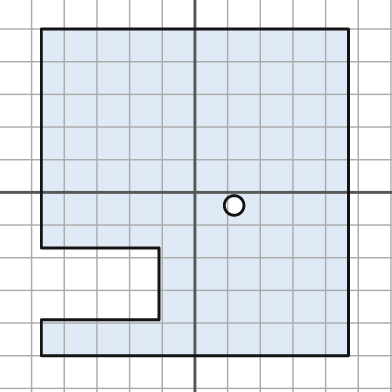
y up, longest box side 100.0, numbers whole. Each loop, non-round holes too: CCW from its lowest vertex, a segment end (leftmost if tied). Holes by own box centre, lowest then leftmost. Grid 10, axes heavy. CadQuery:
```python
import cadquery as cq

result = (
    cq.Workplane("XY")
    .moveTo(-47.0, -50.0)
    .lineTo(47.0, -50.0)
    .lineTo(47.0, 50.0)
    .lineTo(-47.0, 50.0)
    .lineTo(-47.0, -17.0)
    .lineTo(-11.0, -17.0)
    .lineTo(-11.0, -39.0)
    .lineTo(-47.0, -39.0)
    .close()
    .moveTo(12.0, -4.0)
    .circle(3.0)
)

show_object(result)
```